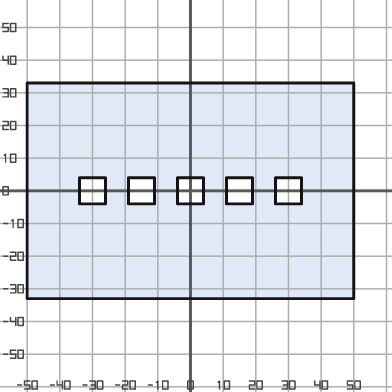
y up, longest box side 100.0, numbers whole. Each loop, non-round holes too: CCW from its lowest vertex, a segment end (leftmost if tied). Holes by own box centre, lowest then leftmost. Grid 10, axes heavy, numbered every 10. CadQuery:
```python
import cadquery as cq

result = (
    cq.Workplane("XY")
    .moveTo(-50.0, -33.0)
    .lineTo(50.0, -33.0)
    .lineTo(50.0, 33.0)
    .lineTo(-50.0, 33.0)
    .close()
    .moveTo(-34.0, -4.0)
    .lineTo(-26.0, -4.0)
    .lineTo(-26.0, 4.0)
    .lineTo(-34.0, 4.0)
    .close()
    .moveTo(-19.0, -4.0)
    .lineTo(-11.0, -4.0)
    .lineTo(-11.0, 4.0)
    .lineTo(-19.0, 4.0)
    .close()
    .moveTo(-4.0, -4.0)
    .lineTo(4.0, -4.0)
    .lineTo(4.0, 4.0)
    .lineTo(-4.0, 4.0)
    .close()
    .moveTo(11.0, -4.0)
    .lineTo(19.0, -4.0)
    .lineTo(19.0, 4.0)
    .lineTo(11.0, 4.0)
    .close()
    .moveTo(26.0, -4.0)
    .lineTo(34.0, -4.0)
    .lineTo(34.0, 4.0)
    .lineTo(26.0, 4.0)
    .close()
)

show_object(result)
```